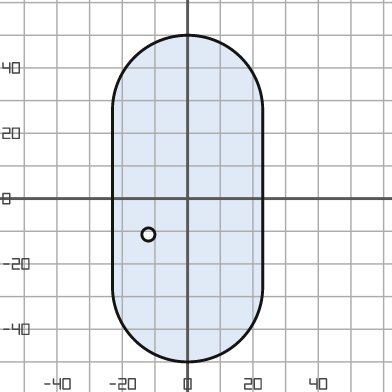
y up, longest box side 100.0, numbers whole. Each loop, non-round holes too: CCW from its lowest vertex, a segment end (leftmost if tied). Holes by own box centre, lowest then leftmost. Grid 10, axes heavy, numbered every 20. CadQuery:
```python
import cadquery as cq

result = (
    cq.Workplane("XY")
    .moveTo(-23.0, -27.0)
    .threePointArc((0.0, -50.0), (23.0, -27.0))
    .lineTo(23.0, 27.0)
    .threePointArc((0.0, 50.0), (-23.0, 27.0))
    .close()
    .moveTo(-12.0, -11.0)
    .circle(2.0)
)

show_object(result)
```